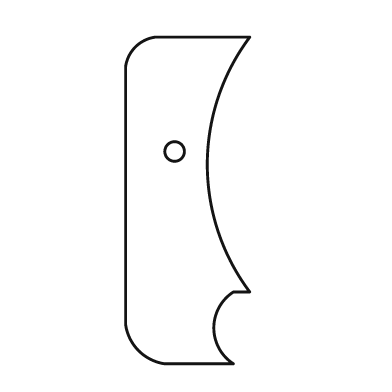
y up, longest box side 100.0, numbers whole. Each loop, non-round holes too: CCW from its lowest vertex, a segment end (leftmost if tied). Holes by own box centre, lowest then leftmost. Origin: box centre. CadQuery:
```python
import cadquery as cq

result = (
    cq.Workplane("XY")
    .moveTo(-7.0, -50.0)
    .lineTo(14.0, -50.0)
    .threePointArc((8.0, -39.0), (14.0, -28.0))
    .lineTo(19.0, -28.0)
    .threePointArc((6.0, 11.0), (19.0, 50.0))
    .lineTo(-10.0, 50.0)
    .threePointArc((-16.0, 47.0), (-19.0, 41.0))
    .lineTo(-19.0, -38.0)
    .threePointArc((-15.0, -46.0), (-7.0, -50.0))
    .close()
    .moveTo(-4.0, 15.0)
    .circle(3.0)
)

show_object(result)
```